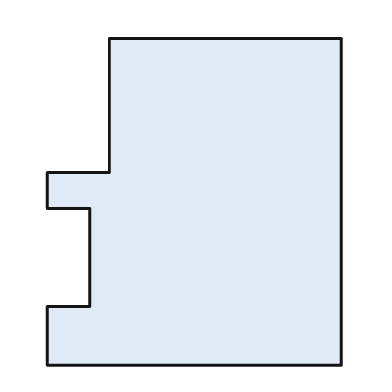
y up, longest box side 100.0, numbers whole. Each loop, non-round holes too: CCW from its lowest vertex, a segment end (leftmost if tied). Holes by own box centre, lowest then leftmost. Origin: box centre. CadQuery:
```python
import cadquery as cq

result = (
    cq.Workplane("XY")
    .moveTo(-45.0, -50.0)
    .lineTo(45.0, -50.0)
    .lineTo(45.0, 50.0)
    .lineTo(-26.0, 50.0)
    .lineTo(-26.0, 9.0)
    .lineTo(-45.0, 9.0)
    .lineTo(-45.0, -2.0)
    .lineTo(-32.0, -2.0)
    .lineTo(-32.0, -32.0)
    .lineTo(-45.0, -32.0)
    .close()
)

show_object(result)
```